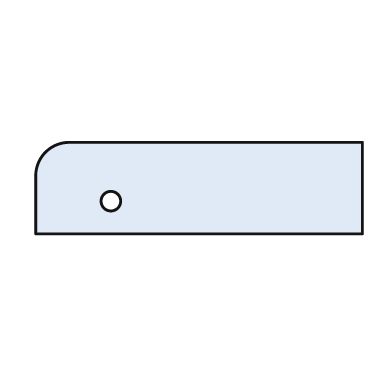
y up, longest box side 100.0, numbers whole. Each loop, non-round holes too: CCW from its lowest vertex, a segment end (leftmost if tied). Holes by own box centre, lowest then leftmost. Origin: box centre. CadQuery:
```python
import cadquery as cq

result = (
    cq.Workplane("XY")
    .moveTo(-50.0, -14.0)
    .lineTo(50.0, -14.0)
    .lineTo(50.0, 14.0)
    .lineTo(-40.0, 14.0)
    .threePointArc((-47.0, 11.0), (-50.0, 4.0))
    .close()
    .moveTo(-27.0, -4.0)
    .circle(3.0)
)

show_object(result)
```